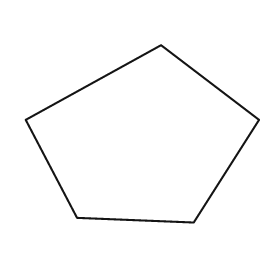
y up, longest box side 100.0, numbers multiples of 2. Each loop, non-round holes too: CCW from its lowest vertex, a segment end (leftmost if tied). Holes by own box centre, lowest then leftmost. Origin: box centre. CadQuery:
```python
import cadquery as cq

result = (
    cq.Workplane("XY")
    .moveTo(22.0, -38.0)
    .lineTo(50.0, 6.0)
    .lineTo(8.0, 38.0)
    .lineTo(-50.0, 6.0)
    .lineTo(-28.0, -36.0)
    .close()
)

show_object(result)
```